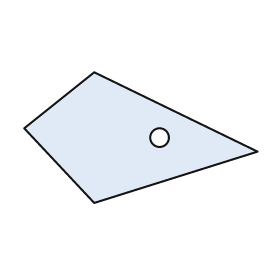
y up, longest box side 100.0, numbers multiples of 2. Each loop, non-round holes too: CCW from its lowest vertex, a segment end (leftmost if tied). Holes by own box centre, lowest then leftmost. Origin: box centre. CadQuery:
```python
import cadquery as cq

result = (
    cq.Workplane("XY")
    .moveTo(-20.0, -28.0)
    .lineTo(50.0, -6.0)
    .lineTo(-20.0, 28.0)
    .lineTo(-50.0, 4.0)
    .close()
    .moveTo(8.0, 0.0)
    .circle(4.0)
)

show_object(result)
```